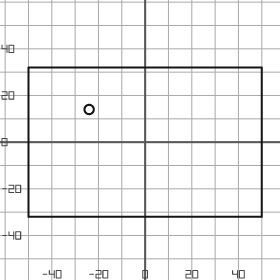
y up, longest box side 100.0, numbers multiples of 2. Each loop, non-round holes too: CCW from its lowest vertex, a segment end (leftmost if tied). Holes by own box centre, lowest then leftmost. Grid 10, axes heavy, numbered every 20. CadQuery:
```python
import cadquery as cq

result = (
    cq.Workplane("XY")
    .moveTo(-50.0, -32.0)
    .lineTo(50.0, -32.0)
    .lineTo(50.0, 32.0)
    .lineTo(-50.0, 32.0)
    .close()
    .moveTo(-24.0, 14.0)
    .circle(2.0)
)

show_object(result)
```